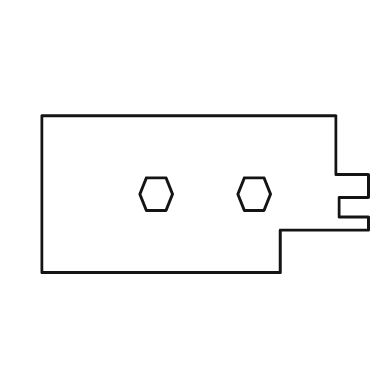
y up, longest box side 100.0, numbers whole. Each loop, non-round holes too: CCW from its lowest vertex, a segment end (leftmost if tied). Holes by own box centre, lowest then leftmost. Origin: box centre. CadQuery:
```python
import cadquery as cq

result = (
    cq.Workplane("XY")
    .moveTo(-50.0, -24.0)
    .lineTo(23.0, -24.0)
    .lineTo(23.0, -11.0)
    .lineTo(50.0, -11.0)
    .lineTo(50.0, -7.0)
    .lineTo(41.0, -7.0)
    .lineTo(41.0, -1.0)
    .lineTo(50.0, -1.0)
    .lineTo(50.0, 6.0)
    .lineTo(40.0, 6.0)
    .lineTo(40.0, 24.0)
    .lineTo(-50.0, 24.0)
    .close()
    .moveTo(-18.0, -5.0)
    .lineTo(-12.0, -5.0)
    .lineTo(-10.0, 0.0)
    .lineTo(-12.0, 5.0)
    .lineTo(-18.0, 5.0)
    .lineTo(-20.0, 0.0)
    .close()
    .moveTo(12.0, -5.0)
    .lineTo(18.0, -5.0)
    .lineTo(20.0, 0.0)
    .lineTo(18.0, 5.0)
    .lineTo(12.0, 5.0)
    .lineTo(10.0, 0.0)
    .close()
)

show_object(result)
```